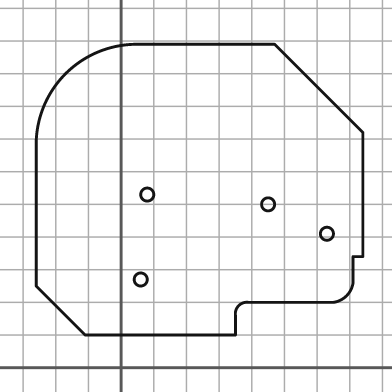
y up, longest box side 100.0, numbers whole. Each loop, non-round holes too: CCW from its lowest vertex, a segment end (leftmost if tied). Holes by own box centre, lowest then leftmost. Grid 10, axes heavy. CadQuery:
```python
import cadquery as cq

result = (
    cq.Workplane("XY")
    .moveTo(-11.0, 10.0)
    .lineTo(35.0, 10.0)
    .lineTo(35.0, 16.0)
    .threePointArc((36.0, 19.0), (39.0, 20.0))
    .lineTo(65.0, 20.0)
    .threePointArc((69.0, 22.0), (71.0, 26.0))
    .lineTo(71.0, 34.0)
    .lineTo(74.0, 34.0)
    .lineTo(74.0, 72.0)
    .lineTo(47.0, 99.0)
    .lineTo(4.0, 99.0)
    .threePointArc((-17.0, 90.0), (-26.0, 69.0))
    .lineTo(-26.0, 25.0)
    .close()
    .moveTo(6.0, 27.0)
    .circle(2.0)
    .moveTo(63.0, 41.0)
    .circle(2.0)
    .moveTo(45.0, 50.0)
    .circle(2.0)
    .moveTo(8.0, 53.0)
    .circle(2.0)
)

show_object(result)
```